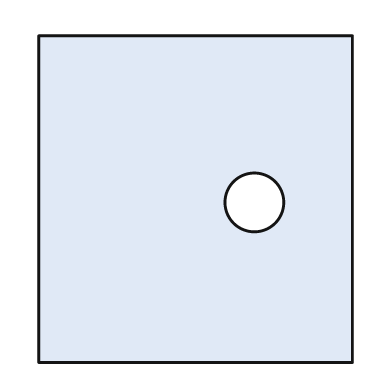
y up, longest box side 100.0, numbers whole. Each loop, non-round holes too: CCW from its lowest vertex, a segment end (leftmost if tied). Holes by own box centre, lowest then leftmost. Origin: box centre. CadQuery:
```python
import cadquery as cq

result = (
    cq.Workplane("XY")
    .moveTo(-48.0, -50.0)
    .lineTo(48.0, -50.0)
    .lineTo(48.0, 50.0)
    .lineTo(-48.0, 50.0)
    .close()
    .moveTo(18.0, -1.0)
    .circle(9.0)
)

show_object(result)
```